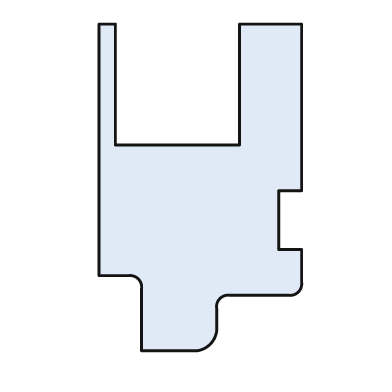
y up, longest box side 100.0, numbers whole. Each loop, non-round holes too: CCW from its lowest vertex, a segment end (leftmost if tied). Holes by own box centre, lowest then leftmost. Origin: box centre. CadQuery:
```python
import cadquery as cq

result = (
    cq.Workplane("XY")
    .moveTo(-18.0, -50.0)
    .lineTo(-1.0, -50.0)
    .threePointArc((3.0, -48.0), (5.0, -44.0))
    .lineTo(5.0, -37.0)
    .threePointArc((6.0, -34.0), (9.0, -33.0))
    .lineTo(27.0, -33.0)
    .threePointArc((30.0, -32.0), (31.0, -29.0))
    .lineTo(31.0, -19.0)
    .lineTo(24.0, -19.0)
    .lineTo(24.0, -1.0)
    .lineTo(31.0, -1.0)
    .lineTo(31.0, 50.0)
    .lineTo(12.0, 50.0)
    .lineTo(12.0, 13.0)
    .lineTo(-26.0, 13.0)
    .lineTo(-26.0, 50.0)
    .lineTo(-31.0, 50.0)
    .lineTo(-31.0, -27.0)
    .lineTo(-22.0, -27.0)
    .threePointArc((-19.0, -28.0), (-18.0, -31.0))
    .close()
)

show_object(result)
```